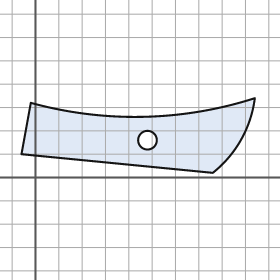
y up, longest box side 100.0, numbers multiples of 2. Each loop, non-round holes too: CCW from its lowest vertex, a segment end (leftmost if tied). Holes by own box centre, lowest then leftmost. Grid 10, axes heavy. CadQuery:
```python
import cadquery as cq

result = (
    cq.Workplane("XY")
    .moveTo(76.0, 2.0)
    .threePointArc((88.0, 16.0), (94.0, 34.0))
    .threePointArc((46.0, 26.0), (-2.0, 32.0))
    .lineTo(-6.0, 10.0)
    .close()
    .moveTo(48.0, 16.0)
    .circle(4.0)
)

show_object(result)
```